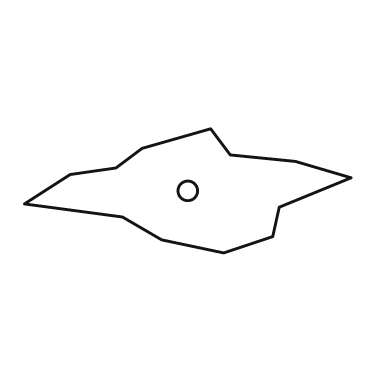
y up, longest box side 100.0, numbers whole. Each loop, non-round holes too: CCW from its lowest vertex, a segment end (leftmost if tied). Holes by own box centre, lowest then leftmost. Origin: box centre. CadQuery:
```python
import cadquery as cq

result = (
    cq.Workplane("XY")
    .moveTo(11.0, -19.0)
    .lineTo(26.0, -14.0)
    .lineTo(28.0, -5.0)
    .lineTo(50.0, 4.0)
    .lineTo(33.0, 9.0)
    .lineTo(13.0, 11.0)
    .lineTo(7.0, 19.0)
    .lineTo(-14.0, 13.0)
    .lineTo(-22.0, 7.0)
    .lineTo(-36.0, 5.0)
    .lineTo(-50.0, -4.0)
    .lineTo(-20.0, -8.0)
    .lineTo(-8.0, -15.0)
    .close()
    .moveTo(0.0, 0.0)
    .circle(3.0)
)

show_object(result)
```